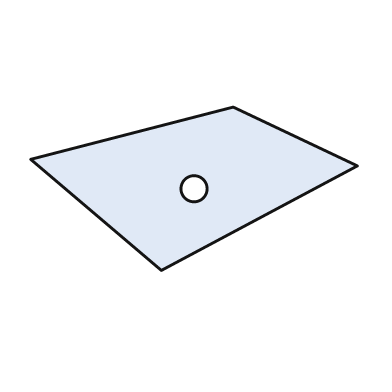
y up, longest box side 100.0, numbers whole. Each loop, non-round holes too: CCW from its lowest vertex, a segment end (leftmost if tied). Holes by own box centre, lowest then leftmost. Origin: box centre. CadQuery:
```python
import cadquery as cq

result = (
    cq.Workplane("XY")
    .moveTo(-10.0, -25.0)
    .lineTo(50.0, 7.0)
    .lineTo(12.0, 25.0)
    .lineTo(-50.0, 9.0)
    .close()
    .moveTo(0.0, 0.0)
    .circle(4.0)
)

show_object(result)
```